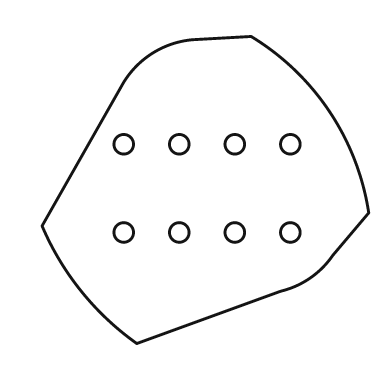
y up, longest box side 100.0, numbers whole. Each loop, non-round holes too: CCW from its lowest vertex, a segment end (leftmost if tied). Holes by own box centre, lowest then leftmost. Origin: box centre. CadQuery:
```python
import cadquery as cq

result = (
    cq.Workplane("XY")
    .moveTo(-21.0, -47.0)
    .lineTo(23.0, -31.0)
    .threePointArc((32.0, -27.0), (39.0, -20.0))
    .lineTo(50.0, -7.0)
    .threePointArc((38.0, 24.0), (14.0, 47.0))
    .lineTo(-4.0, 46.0)
    .threePointArc((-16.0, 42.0), (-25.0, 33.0))
    .lineTo(-50.0, -11.0)
    .threePointArc((-38.0, -31.0), (-21.0, -47.0))
    .close()
    .moveTo(-25.0, -13.0)
    .circle(3.0)
    .moveTo(-8.0, -13.0)
    .circle(3.0)
    .moveTo(9.0, -13.0)
    .circle(3.0)
    .moveTo(26.0, -13.0)
    .circle(3.0)
    .moveTo(-25.0, 14.0)
    .circle(3.0)
    .moveTo(-8.0, 14.0)
    .circle(3.0)
    .moveTo(9.0, 14.0)
    .circle(3.0)
    .moveTo(26.0, 14.0)
    .circle(3.0)
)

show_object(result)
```